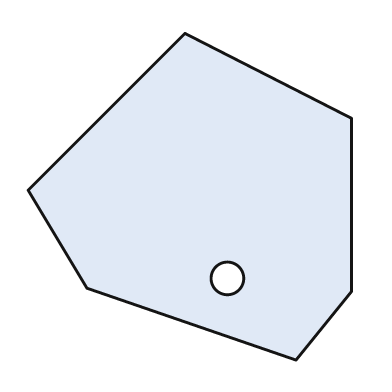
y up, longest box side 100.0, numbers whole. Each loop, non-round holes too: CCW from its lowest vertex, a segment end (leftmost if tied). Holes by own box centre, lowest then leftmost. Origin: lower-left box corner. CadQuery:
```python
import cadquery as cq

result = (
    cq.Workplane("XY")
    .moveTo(82.0, 0.0)
    .lineTo(99.0, 21.0)
    .lineTo(99.0, 74.0)
    .lineTo(48.0, 100.0)
    .lineTo(0.0, 52.0)
    .lineTo(18.0, 22.0)
    .close()
    .moveTo(61.0, 25.0)
    .circle(5.0)
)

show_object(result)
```